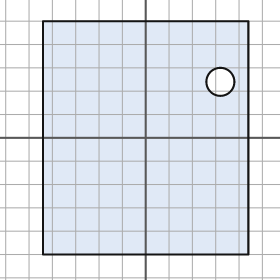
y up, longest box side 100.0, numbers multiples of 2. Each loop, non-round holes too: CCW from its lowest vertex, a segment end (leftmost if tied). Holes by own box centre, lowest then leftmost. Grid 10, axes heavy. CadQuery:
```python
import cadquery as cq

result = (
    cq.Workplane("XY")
    .moveTo(-44.0, -50.0)
    .lineTo(44.0, -50.0)
    .lineTo(44.0, 50.0)
    .lineTo(-44.0, 50.0)
    .close()
    .moveTo(32.0, 24.0)
    .circle(6.0)
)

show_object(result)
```